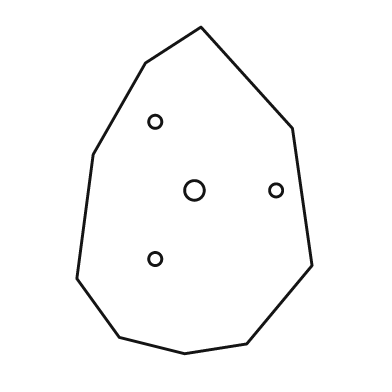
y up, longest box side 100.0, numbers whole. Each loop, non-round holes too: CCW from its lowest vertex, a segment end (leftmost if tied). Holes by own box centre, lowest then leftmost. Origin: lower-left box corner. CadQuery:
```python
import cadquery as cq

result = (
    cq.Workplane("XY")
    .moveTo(33.0, 0.0)
    .lineTo(52.0, 3.0)
    .lineTo(72.0, 27.0)
    .lineTo(66.0, 69.0)
    .lineTo(38.0, 100.0)
    .lineTo(21.0, 89.0)
    .lineTo(5.0, 61.0)
    .lineTo(0.0, 23.0)
    .lineTo(13.0, 5.0)
    .close()
    .moveTo(24.0, 29.0)
    .circle(2.0)
    .moveTo(36.0, 50.0)
    .circle(3.0)
    .moveTo(61.0, 50.0)
    .circle(2.0)
    .moveTo(24.0, 71.0)
    .circle(2.0)
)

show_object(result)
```